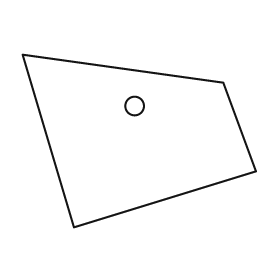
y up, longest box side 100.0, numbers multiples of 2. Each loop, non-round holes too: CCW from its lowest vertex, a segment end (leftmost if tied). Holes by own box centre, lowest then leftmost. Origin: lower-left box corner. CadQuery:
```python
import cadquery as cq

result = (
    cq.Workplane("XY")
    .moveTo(22.0, 0.0)
    .lineTo(100.0, 24.0)
    .lineTo(86.0, 62.0)
    .lineTo(0.0, 74.0)
    .close()
    .moveTo(48.0, 52.0)
    .circle(4.0)
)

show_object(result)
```